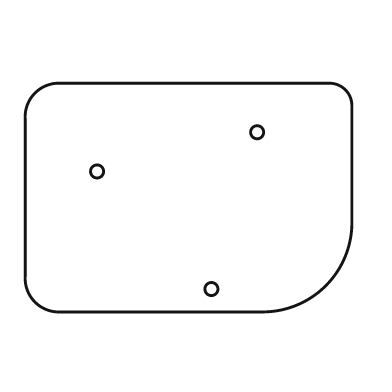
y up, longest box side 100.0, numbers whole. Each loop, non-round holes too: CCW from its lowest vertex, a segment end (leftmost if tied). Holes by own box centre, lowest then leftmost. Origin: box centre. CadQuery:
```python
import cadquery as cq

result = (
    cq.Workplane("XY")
    .moveTo(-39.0, -35.0)
    .lineTo(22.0, -35.0)
    .threePointArc((42.0, -27.0), (50.0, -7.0))
    .lineTo(50.0, 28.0)
    .threePointArc((48.0, 33.0), (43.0, 35.0))
    .lineTo(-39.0, 35.0)
    .threePointArc((-47.0, 32.0), (-50.0, 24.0))
    .lineTo(-50.0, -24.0)
    .threePointArc((-47.0, -32.0), (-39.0, -35.0))
    .close()
    .moveTo(7.0, -28.0)
    .circle(2.0)
    .moveTo(-28.0, 8.0)
    .circle(2.0)
    .moveTo(21.0, 20.0)
    .circle(2.0)
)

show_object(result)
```